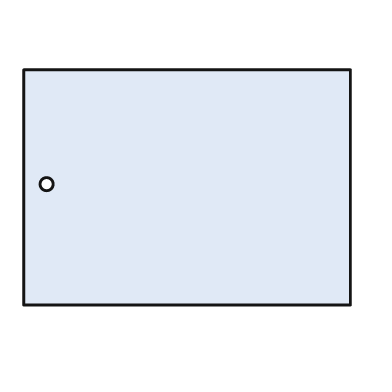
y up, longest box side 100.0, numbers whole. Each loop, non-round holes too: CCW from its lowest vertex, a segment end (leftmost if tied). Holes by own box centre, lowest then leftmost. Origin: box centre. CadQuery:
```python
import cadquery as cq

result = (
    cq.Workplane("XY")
    .moveTo(-50.0, -36.0)
    .lineTo(50.0, -36.0)
    .lineTo(50.0, 36.0)
    .lineTo(-50.0, 36.0)
    .close()
    .moveTo(-43.0, 1.0)
    .circle(2.0)
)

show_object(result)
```